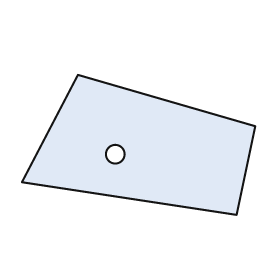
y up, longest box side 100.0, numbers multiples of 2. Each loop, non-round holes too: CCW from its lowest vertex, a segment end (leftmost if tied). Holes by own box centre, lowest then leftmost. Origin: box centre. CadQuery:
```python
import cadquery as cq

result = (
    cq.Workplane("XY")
    .moveTo(42.0, -30.0)
    .lineTo(50.0, 8.0)
    .lineTo(-26.0, 30.0)
    .lineTo(-50.0, -16.0)
    .close()
    .moveTo(-10.0, -4.0)
    .circle(4.0)
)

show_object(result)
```